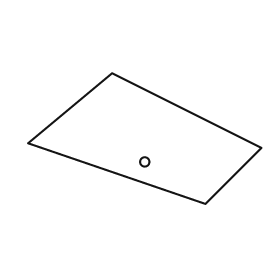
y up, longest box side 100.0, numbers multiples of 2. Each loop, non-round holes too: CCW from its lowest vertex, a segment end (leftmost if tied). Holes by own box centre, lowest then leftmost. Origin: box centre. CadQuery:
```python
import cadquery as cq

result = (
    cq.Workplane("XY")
    .moveTo(26.0, -28.0)
    .lineTo(50.0, -4.0)
    .lineTo(-14.0, 28.0)
    .lineTo(-50.0, -2.0)
    .close()
    .moveTo(0.0, -10.0)
    .circle(2.0)
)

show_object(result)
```